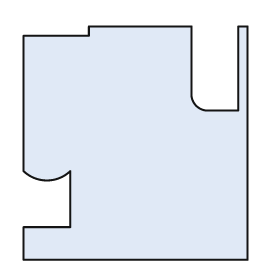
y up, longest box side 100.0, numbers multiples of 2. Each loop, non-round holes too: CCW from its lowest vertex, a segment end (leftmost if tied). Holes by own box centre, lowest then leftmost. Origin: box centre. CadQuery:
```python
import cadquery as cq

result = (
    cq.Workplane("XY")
    .moveTo(-48.0, -50.0)
    .lineTo(48.0, -50.0)
    .lineTo(48.0, 50.0)
    .lineTo(44.0, 50.0)
    .lineTo(44.0, 14.0)
    .lineTo(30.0, 14.0)
    .threePointArc((26.0, 16.0), (24.0, 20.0))
    .lineTo(24.0, 50.0)
    .lineTo(-20.0, 50.0)
    .lineTo(-20.0, 46.0)
    .lineTo(-48.0, 46.0)
    .lineTo(-48.0, -12.0)
    .threePointArc((-38.0, -16.0), (-28.0, -12.0))
    .lineTo(-28.0, -36.0)
    .lineTo(-48.0, -36.0)
    .close()
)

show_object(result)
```